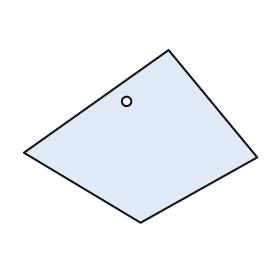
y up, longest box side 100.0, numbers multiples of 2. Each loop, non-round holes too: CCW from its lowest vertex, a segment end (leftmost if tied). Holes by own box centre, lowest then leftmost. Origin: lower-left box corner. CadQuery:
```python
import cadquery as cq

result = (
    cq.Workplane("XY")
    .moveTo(50.0, 0.0)
    .lineTo(100.0, 28.0)
    .lineTo(62.0, 74.0)
    .lineTo(0.0, 30.0)
    .close()
    .moveTo(44.0, 52.0)
    .circle(2.0)
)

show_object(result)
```